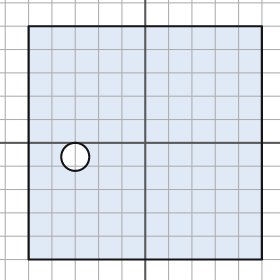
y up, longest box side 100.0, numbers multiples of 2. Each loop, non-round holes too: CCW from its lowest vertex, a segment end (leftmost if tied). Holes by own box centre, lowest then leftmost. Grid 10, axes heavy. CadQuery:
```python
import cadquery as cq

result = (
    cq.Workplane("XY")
    .moveTo(-50.0, -50.0)
    .lineTo(50.0, -50.0)
    .lineTo(50.0, 50.0)
    .lineTo(-50.0, 50.0)
    .close()
    .moveTo(-30.0, -6.0)
    .circle(6.0)
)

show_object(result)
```